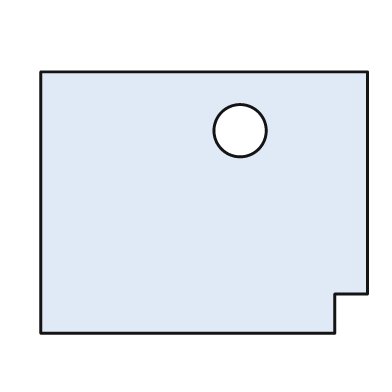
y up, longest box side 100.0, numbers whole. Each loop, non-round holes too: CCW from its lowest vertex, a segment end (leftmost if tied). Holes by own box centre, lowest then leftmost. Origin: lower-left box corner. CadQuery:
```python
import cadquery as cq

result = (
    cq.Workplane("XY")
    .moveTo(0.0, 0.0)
    .lineTo(90.0, 0.0)
    .lineTo(90.0, 12.0)
    .lineTo(100.0, 12.0)
    .lineTo(100.0, 80.0)
    .lineTo(0.0, 80.0)
    .close()
    .moveTo(61.0, 62.0)
    .circle(8.0)
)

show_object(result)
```